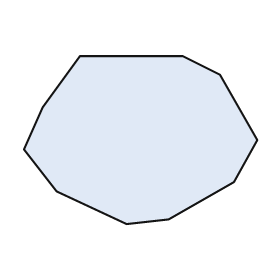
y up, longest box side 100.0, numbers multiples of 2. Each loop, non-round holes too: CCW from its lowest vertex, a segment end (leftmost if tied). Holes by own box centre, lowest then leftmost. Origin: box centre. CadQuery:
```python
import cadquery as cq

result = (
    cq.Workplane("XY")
    .moveTo(-6.0, -36.0)
    .lineTo(12.0, -34.0)
    .lineTo(40.0, -18.0)
    .lineTo(50.0, 0.0)
    .lineTo(34.0, 28.0)
    .lineTo(18.0, 36.0)
    .lineTo(-26.0, 36.0)
    .lineTo(-42.0, 14.0)
    .lineTo(-50.0, -4.0)
    .lineTo(-36.0, -22.0)
    .close()
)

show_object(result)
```